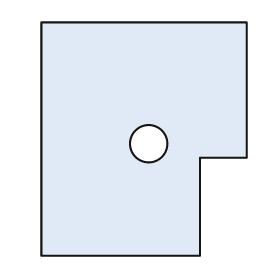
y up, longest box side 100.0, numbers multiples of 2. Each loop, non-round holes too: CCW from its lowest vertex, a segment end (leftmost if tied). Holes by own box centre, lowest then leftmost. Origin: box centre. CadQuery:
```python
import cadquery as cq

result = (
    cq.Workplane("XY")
    .moveTo(-44.0, -50.0)
    .lineTo(24.0, -50.0)
    .lineTo(24.0, -8.0)
    .lineTo(44.0, -8.0)
    .lineTo(44.0, 50.0)
    .lineTo(-44.0, 50.0)
    .close()
    .moveTo(2.0, -2.0)
    .circle(8.0)
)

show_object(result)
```